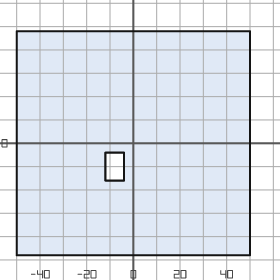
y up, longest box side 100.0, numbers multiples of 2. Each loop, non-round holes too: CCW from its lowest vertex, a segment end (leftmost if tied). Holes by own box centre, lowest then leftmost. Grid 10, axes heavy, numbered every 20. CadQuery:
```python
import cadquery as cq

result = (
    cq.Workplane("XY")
    .moveTo(-50.0, -48.0)
    .lineTo(50.0, -48.0)
    .lineTo(50.0, 48.0)
    .lineTo(-50.0, 48.0)
    .close()
    .moveTo(-12.0, -16.0)
    .lineTo(-4.0, -16.0)
    .lineTo(-4.0, -4.0)
    .lineTo(-12.0, -4.0)
    .close()
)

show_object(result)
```